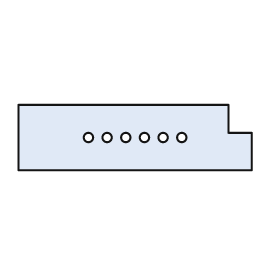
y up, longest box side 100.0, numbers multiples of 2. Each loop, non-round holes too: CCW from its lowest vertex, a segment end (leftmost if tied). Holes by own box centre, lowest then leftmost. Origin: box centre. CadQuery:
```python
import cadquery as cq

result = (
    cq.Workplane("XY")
    .moveTo(-50.0, -14.0)
    .lineTo(50.0, -14.0)
    .lineTo(50.0, 2.0)
    .lineTo(40.0, 2.0)
    .lineTo(40.0, 14.0)
    .lineTo(-50.0, 14.0)
    .close()
    .moveTo(-20.0, 0.0)
    .circle(2.0)
    .moveTo(-12.0, 0.0)
    .circle(2.0)
    .moveTo(-4.0, 0.0)
    .circle(2.0)
    .moveTo(4.0, 0.0)
    .circle(2.0)
    .moveTo(12.0, 0.0)
    .circle(2.0)
    .moveTo(20.0, 0.0)
    .circle(2.0)
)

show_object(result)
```